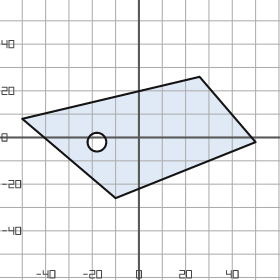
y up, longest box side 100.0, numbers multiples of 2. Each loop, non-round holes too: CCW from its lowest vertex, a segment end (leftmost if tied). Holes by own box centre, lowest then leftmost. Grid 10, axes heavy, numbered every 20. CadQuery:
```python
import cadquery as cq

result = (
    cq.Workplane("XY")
    .moveTo(-10.0, -26.0)
    .lineTo(50.0, -2.0)
    .lineTo(26.0, 26.0)
    .lineTo(-50.0, 8.0)
    .close()
    .moveTo(-18.0, -2.0)
    .circle(4.0)
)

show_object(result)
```